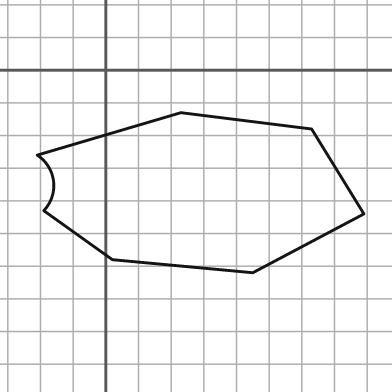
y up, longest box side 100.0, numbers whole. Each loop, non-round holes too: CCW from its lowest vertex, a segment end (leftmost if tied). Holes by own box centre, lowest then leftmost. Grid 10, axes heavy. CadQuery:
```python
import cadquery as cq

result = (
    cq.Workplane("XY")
    .moveTo(45.0, -62.0)
    .lineTo(79.0, -44.0)
    .lineTo(63.0, -18.0)
    .lineTo(23.0, -13.0)
    .lineTo(-21.0, -26.0)
    .threePointArc((-16.0, -34.0), (-19.0, -43.0))
    .lineTo(2.0, -58.0)
    .close()
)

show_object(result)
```